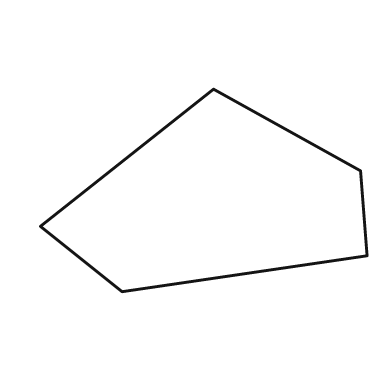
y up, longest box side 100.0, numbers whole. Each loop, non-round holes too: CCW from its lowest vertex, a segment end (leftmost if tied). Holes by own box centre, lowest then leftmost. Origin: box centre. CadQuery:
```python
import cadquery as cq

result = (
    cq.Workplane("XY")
    .moveTo(-25.0, -31.0)
    .lineTo(50.0, -20.0)
    .lineTo(48.0, 6.0)
    .lineTo(3.0, 31.0)
    .lineTo(-50.0, -11.0)
    .close()
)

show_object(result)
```